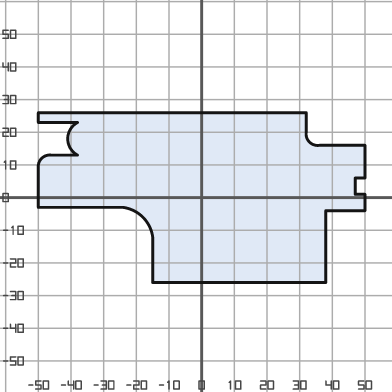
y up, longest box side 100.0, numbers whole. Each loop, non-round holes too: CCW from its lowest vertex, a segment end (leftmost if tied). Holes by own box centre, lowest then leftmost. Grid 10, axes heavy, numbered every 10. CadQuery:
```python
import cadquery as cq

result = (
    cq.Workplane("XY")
    .moveTo(-15.0, -26.0)
    .lineTo(38.0, -26.0)
    .lineTo(38.0, -4.0)
    .lineTo(50.0, -4.0)
    .lineTo(50.0, 1.0)
    .lineTo(47.0, 1.0)
    .lineTo(47.0, 6.0)
    .lineTo(50.0, 6.0)
    .lineTo(50.0, 16.0)
    .lineTo(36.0, 16.0)
    .threePointArc((33.0, 17.0), (32.0, 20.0))
    .lineTo(32.0, 26.0)
    .lineTo(-50.0, 26.0)
    .lineTo(-50.0, 23.0)
    .lineTo(-38.0, 23.0)
    .threePointArc((-41.0, 18.0), (-38.0, 13.0))
    .lineTo(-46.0, 13.0)
    .threePointArc((-49.0, 12.0), (-50.0, 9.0))
    .lineTo(-50.0, -3.0)
    .lineTo(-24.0, -3.0)
    .threePointArc((-18.0, -6.0), (-15.0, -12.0))
    .close()
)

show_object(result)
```